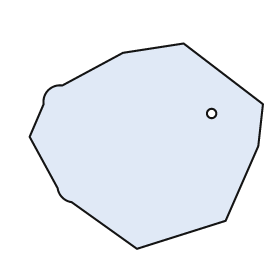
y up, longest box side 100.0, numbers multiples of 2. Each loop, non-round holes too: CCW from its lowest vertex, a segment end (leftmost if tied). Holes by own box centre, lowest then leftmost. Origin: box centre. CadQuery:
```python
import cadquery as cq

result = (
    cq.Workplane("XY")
    .moveTo(-4.0, -44.0)
    .lineTo(34.0, -32.0)
    .lineTo(48.0, 0.0)
    .lineTo(50.0, 18.0)
    .lineTo(16.0, 44.0)
    .lineTo(-10.0, 40.0)
    .lineTo(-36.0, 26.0)
    .threePointArc((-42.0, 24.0), (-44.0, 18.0))
    .lineTo(-50.0, 4.0)
    .lineTo(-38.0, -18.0)
    .threePointArc((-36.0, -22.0), (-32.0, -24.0))
    .close()
    .moveTo(28.0, 14.0)
    .circle(2.0)
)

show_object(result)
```